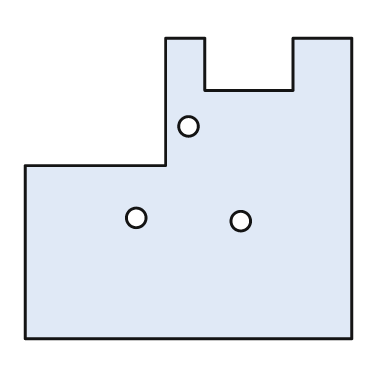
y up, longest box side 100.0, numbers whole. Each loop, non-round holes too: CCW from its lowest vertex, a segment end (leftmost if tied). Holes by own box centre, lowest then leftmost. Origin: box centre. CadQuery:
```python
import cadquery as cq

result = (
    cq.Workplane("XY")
    .moveTo(-50.0, -46.0)
    .lineTo(50.0, -46.0)
    .lineTo(50.0, 46.0)
    .lineTo(32.0, 46.0)
    .lineTo(32.0, 30.0)
    .lineTo(5.0, 30.0)
    .lineTo(5.0, 46.0)
    .lineTo(-7.0, 46.0)
    .lineTo(-7.0, 7.0)
    .lineTo(-50.0, 7.0)
    .close()
    .moveTo(16.0, -10.0)
    .circle(3.0)
    .moveTo(-16.0, -9.0)
    .circle(3.0)
    .moveTo(0.0, 19.0)
    .circle(3.0)
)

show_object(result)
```